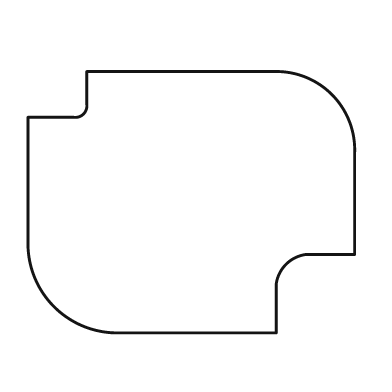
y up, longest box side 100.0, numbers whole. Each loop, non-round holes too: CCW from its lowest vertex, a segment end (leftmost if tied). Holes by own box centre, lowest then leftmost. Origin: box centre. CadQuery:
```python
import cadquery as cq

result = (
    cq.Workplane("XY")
    .moveTo(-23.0, -40.0)
    .lineTo(26.0, -40.0)
    .lineTo(26.0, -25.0)
    .threePointArc((29.0, -19.0), (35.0, -16.0))
    .lineTo(50.0, -16.0)
    .lineTo(50.0, 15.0)
    .threePointArc((43.0, 33.0), (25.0, 40.0))
    .lineTo(-32.0, 40.0)
    .lineTo(-32.0, 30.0)
    .threePointArc((-33.0, 27.0), (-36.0, 26.0))
    .lineTo(-50.0, 26.0)
    .lineTo(-50.0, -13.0)
    .threePointArc((-42.0, -32.0), (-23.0, -40.0))
    .close()
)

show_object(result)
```